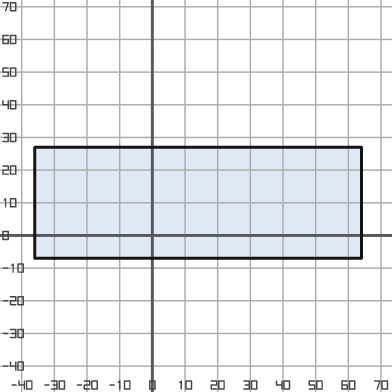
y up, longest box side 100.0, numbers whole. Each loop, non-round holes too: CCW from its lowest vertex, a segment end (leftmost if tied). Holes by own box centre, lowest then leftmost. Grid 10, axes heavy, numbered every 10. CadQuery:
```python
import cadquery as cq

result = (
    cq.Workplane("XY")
    .moveTo(-36.0, -7.0)
    .lineTo(64.0, -7.0)
    .lineTo(64.0, 27.0)
    .lineTo(-36.0, 27.0)
    .close()
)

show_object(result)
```